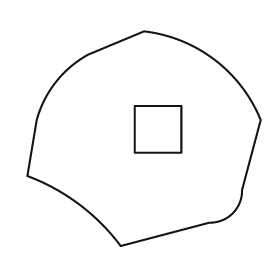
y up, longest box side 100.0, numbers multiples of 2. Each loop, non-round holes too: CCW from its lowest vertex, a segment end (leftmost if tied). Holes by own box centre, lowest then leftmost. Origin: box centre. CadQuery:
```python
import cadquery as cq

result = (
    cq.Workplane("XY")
    .moveTo(-10.0, -46.0)
    .lineTo(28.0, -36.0)
    .threePointArc((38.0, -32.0), (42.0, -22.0))
    .lineTo(50.0, 8.0)
    .threePointArc((30.0, 34.0), (0.0, 46.0))
    .lineTo(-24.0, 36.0)
    .threePointArc((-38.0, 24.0), (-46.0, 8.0))
    .lineTo(-50.0, -16.0)
    .threePointArc((-28.0, -28.0), (-10.0, -46.0))
    .close()
    .moveTo(-4.0, -6.0)
    .lineTo(16.0, -6.0)
    .lineTo(16.0, 14.0)
    .lineTo(-4.0, 14.0)
    .close()
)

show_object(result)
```